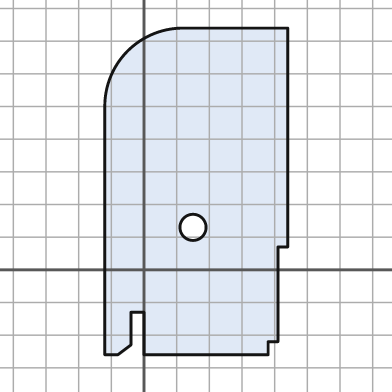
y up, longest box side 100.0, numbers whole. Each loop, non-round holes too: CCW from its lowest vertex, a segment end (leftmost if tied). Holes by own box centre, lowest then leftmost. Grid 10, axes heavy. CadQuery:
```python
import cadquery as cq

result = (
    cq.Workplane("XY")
    .moveTo(-12.0, -26.0)
    .lineTo(-8.0, -26.0)
    .lineTo(-4.0, -23.0)
    .lineTo(-4.0, -13.0)
    .lineTo(0.0, -13.0)
    .lineTo(0.0, -26.0)
    .lineTo(38.0, -26.0)
    .lineTo(38.0, -22.0)
    .lineTo(41.0, -22.0)
    .lineTo(41.0, 7.0)
    .lineTo(44.0, 7.0)
    .lineTo(44.0, 74.0)
    .lineTo(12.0, 74.0)
    .threePointArc((-5.0, 67.0), (-12.0, 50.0))
    .close()
    .moveTo(15.0, 13.0)
    .circle(4.0)
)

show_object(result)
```